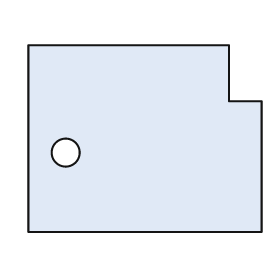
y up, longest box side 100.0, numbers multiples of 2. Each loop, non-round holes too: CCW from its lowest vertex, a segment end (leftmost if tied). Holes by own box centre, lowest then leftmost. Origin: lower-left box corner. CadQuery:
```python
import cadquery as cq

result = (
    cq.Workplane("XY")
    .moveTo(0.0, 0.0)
    .lineTo(100.0, 0.0)
    .lineTo(100.0, 56.0)
    .lineTo(86.0, 56.0)
    .lineTo(86.0, 80.0)
    .lineTo(0.0, 80.0)
    .close()
    .moveTo(16.0, 34.0)
    .circle(6.0)
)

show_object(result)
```